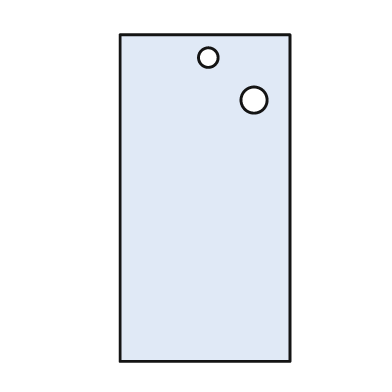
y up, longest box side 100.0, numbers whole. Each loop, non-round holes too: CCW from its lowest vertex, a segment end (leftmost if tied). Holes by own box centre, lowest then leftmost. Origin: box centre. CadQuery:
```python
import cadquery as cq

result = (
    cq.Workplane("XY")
    .moveTo(-26.0, -50.0)
    .lineTo(26.0, -50.0)
    .lineTo(26.0, 50.0)
    .lineTo(-26.0, 50.0)
    .close()
    .moveTo(15.0, 30.0)
    .circle(4.0)
    .moveTo(1.0, 43.0)
    .circle(3.0)
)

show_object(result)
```